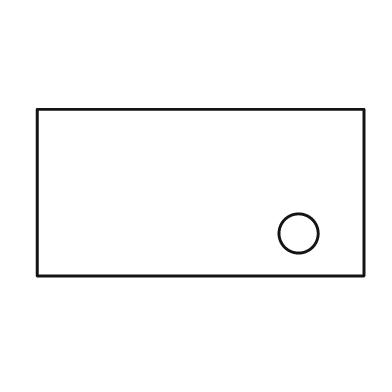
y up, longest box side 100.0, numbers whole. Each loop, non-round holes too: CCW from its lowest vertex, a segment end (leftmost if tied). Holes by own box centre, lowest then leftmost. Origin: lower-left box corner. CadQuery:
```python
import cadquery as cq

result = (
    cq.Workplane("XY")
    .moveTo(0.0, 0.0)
    .lineTo(100.0, 0.0)
    .lineTo(100.0, 51.0)
    .lineTo(0.0, 51.0)
    .close()
    .moveTo(80.0, 13.0)
    .circle(6.0)
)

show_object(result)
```